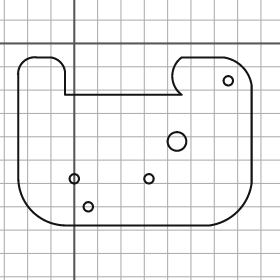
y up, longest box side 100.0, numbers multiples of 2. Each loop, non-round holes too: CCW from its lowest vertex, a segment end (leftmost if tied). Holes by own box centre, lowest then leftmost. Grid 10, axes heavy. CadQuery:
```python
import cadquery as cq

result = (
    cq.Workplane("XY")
    .moveTo(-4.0, -78.0)
    .lineTo(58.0, -78.0)
    .threePointArc((70.0, -72.0), (76.0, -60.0))
    .lineTo(76.0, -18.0)
    .threePointArc((72.0, -10.0), (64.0, -6.0))
    .lineTo(46.0, -6.0)
    .threePointArc((42.0, -14.0), (46.0, -22.0))
    .lineTo(-4.0, -22.0)
    .lineTo(-4.0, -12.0)
    .threePointArc((-6.0, -8.0), (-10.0, -6.0))
    .lineTo(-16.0, -6.0)
    .threePointArc((-22.0, -8.0), (-24.0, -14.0))
    .lineTo(-24.0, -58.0)
    .threePointArc((-18.0, -72.0), (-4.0, -78.0))
    .close()
    .moveTo(6.0, -70.0)
    .circle(2.0)
    .moveTo(0.0, -58.0)
    .circle(2.0)
    .moveTo(32.0, -58.0)
    .circle(2.0)
    .moveTo(44.0, -42.0)
    .circle(4.0)
    .moveTo(66.0, -16.0)
    .circle(2.0)
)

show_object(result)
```